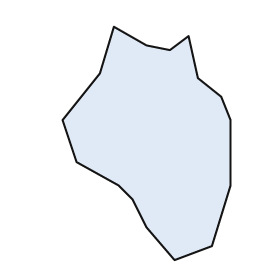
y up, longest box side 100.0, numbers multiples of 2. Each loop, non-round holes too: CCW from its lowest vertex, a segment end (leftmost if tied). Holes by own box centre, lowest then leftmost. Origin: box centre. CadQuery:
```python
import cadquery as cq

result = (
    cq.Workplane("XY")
    .moveTo(12.0, -50.0)
    .lineTo(28.0, -44.0)
    .lineTo(36.0, -18.0)
    .lineTo(36.0, 10.0)
    .lineTo(32.0, 20.0)
    .lineTo(22.0, 28.0)
    .lineTo(18.0, 46.0)
    .lineTo(10.0, 40.0)
    .lineTo(0.0, 42.0)
    .lineTo(-14.0, 50.0)
    .lineTo(-20.0, 30.0)
    .lineTo(-36.0, 10.0)
    .lineTo(-30.0, -8.0)
    .lineTo(-12.0, -18.0)
    .lineTo(-6.0, -24.0)
    .lineTo(0.0, -36.0)
    .close()
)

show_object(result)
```